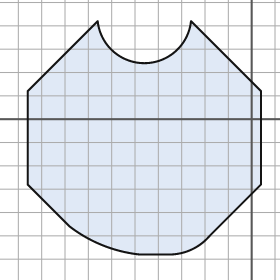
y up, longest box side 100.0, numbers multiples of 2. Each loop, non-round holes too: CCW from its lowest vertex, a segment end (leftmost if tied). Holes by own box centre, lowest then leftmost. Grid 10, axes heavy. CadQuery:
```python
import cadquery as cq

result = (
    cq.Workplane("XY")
    .moveTo(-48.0, -58.0)
    .lineTo(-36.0, -58.0)
    .threePointArc((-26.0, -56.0), (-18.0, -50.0))
    .lineTo(4.0, -28.0)
    .lineTo(4.0, 12.0)
    .lineTo(-26.0, 42.0)
    .threePointArc((-46.0, 24.0), (-66.0, 42.0))
    .lineTo(-96.0, 12.0)
    .lineTo(-96.0, -28.0)
    .lineTo(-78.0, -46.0)
    .threePointArc((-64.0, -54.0), (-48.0, -58.0))
    .close()
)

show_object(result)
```